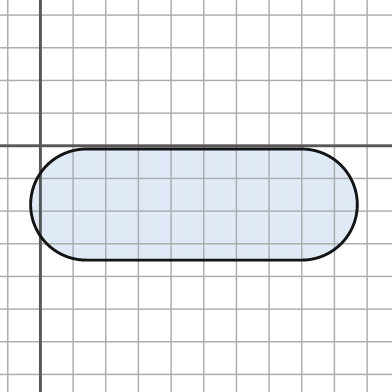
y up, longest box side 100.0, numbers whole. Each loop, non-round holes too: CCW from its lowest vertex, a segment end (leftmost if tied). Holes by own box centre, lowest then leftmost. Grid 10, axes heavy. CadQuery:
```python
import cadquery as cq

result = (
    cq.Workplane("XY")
    .moveTo(14.0, -35.0)
    .lineTo(80.0, -35.0)
    .threePointArc((97.0, -18.0), (80.0, -1.0))
    .lineTo(14.0, -1.0)
    .threePointArc((-3.0, -18.0), (14.0, -35.0))
    .close()
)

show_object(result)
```